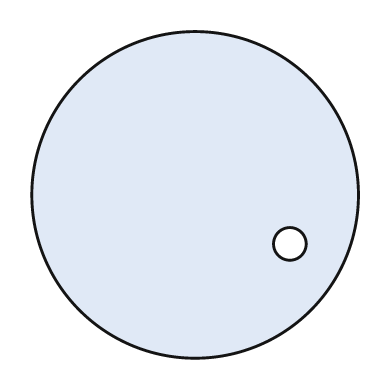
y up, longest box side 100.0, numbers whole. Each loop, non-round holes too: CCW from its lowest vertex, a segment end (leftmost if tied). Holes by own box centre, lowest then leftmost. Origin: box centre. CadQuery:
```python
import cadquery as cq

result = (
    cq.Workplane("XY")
    .moveTo(0.0, 0.0)
    .circle(50.0)
    .moveTo(29.0, -15.0)
    .circle(5.0)
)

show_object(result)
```